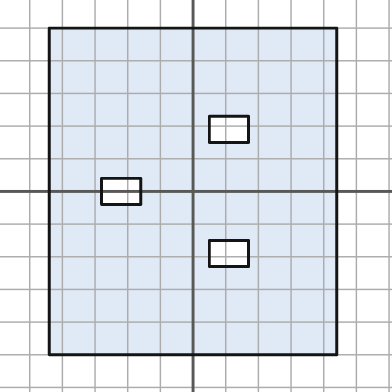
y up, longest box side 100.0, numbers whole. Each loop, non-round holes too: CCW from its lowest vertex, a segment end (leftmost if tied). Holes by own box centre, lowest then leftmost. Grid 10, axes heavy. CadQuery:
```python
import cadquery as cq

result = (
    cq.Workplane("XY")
    .moveTo(-44.0, -50.0)
    .lineTo(44.0, -50.0)
    .lineTo(44.0, 50.0)
    .lineTo(-44.0, 50.0)
    .close()
    .moveTo(5.0, -23.0)
    .lineTo(17.0, -23.0)
    .lineTo(17.0, -15.0)
    .lineTo(5.0, -15.0)
    .close()
    .moveTo(-28.0, -4.0)
    .lineTo(-16.0, -4.0)
    .lineTo(-16.0, 4.0)
    .lineTo(-28.0, 4.0)
    .close()
    .moveTo(5.0, 15.0)
    .lineTo(17.0, 15.0)
    .lineTo(17.0, 23.0)
    .lineTo(5.0, 23.0)
    .close()
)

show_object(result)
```